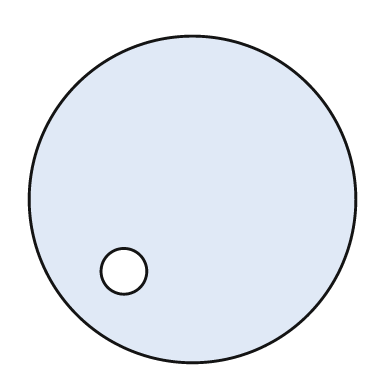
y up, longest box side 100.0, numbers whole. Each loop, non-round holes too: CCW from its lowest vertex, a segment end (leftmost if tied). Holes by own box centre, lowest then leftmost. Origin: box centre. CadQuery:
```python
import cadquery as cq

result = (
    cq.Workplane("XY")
    .moveTo(0.0, 0.0)
    .circle(50.0)
    .moveTo(-21.0, -22.0)
    .circle(7.0)
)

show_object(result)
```